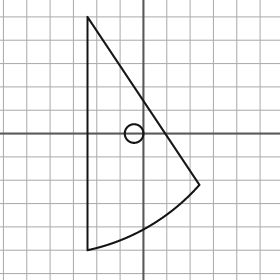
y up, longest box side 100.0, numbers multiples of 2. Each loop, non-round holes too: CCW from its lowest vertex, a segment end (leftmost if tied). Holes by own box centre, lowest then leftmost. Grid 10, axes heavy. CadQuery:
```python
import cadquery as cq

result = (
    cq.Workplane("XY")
    .moveTo(-24.0, -50.0)
    .threePointArc((2.0, -40.0), (24.0, -22.0))
    .lineTo(-24.0, 50.0)
    .close()
    .moveTo(-4.0, 0.0)
    .circle(4.0)
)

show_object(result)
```